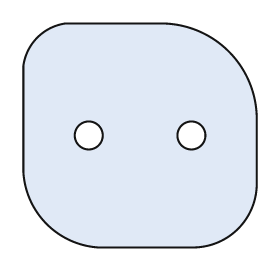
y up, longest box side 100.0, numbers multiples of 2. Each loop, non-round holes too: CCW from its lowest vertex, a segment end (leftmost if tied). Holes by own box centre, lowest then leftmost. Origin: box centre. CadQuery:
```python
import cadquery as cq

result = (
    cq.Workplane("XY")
    .moveTo(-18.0, -48.0)
    .lineTo(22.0, -48.0)
    .threePointArc((42.0, -40.0), (50.0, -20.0))
    .lineTo(50.0, 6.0)
    .threePointArc((38.0, 36.0), (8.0, 48.0))
    .lineTo(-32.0, 48.0)
    .threePointArc((-44.0, 42.0), (-50.0, 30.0))
    .lineTo(-50.0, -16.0)
    .threePointArc((-40.0, -38.0), (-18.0, -48.0))
    .close()
    .moveTo(-22.0, 0.0)
    .circle(6.0)
    .moveTo(22.0, 0.0)
    .circle(6.0)
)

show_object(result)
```